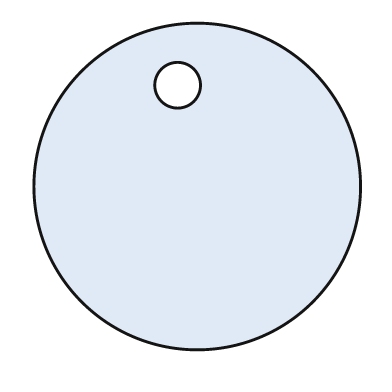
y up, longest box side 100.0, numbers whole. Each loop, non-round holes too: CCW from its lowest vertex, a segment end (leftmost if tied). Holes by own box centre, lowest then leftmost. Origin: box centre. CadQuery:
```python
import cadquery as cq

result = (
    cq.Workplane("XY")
    .moveTo(0.0, 0.0)
    .circle(50.0)
    .moveTo(-6.0, 31.0)
    .circle(7.0)
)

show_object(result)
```